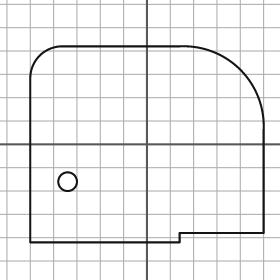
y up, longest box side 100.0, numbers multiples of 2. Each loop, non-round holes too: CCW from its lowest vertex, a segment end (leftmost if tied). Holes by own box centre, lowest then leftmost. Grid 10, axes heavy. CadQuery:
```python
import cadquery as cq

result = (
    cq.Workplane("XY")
    .moveTo(-50.0, -42.0)
    .lineTo(14.0, -42.0)
    .lineTo(14.0, -38.0)
    .lineTo(50.0, -38.0)
    .lineTo(50.0, 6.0)
    .threePointArc((40.0, 32.0), (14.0, 42.0))
    .lineTo(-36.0, 42.0)
    .threePointArc((-46.0, 38.0), (-50.0, 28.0))
    .close()
    .moveTo(-34.0, -16.0)
    .circle(4.0)
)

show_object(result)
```